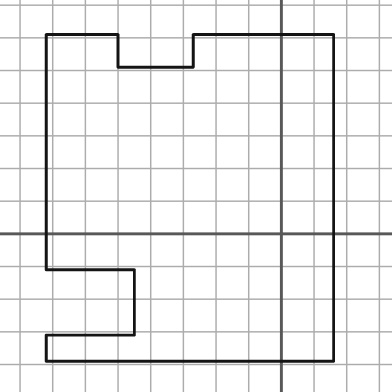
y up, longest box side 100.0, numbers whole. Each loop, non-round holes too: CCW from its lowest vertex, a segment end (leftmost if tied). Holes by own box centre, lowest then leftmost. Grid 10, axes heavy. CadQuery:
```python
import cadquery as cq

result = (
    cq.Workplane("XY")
    .moveTo(-72.0, -39.0)
    .lineTo(16.0, -39.0)
    .lineTo(16.0, 61.0)
    .lineTo(-27.0, 61.0)
    .lineTo(-27.0, 51.0)
    .lineTo(-50.0, 51.0)
    .lineTo(-50.0, 61.0)
    .lineTo(-72.0, 61.0)
    .lineTo(-72.0, -11.0)
    .lineTo(-45.0, -11.0)
    .lineTo(-45.0, -31.0)
    .lineTo(-72.0, -31.0)
    .close()
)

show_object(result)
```